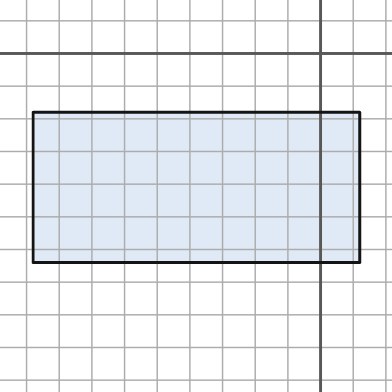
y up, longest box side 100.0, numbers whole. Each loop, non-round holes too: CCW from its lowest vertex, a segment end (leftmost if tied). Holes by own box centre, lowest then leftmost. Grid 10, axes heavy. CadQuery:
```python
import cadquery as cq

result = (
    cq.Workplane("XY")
    .moveTo(-88.0, -64.0)
    .lineTo(12.0, -64.0)
    .lineTo(12.0, -18.0)
    .lineTo(-88.0, -18.0)
    .close()
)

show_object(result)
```